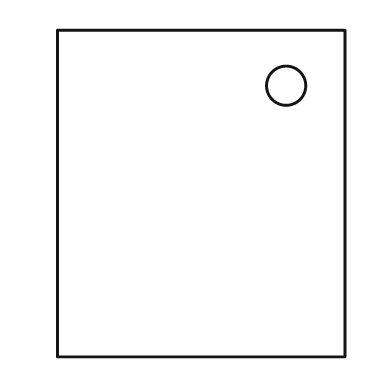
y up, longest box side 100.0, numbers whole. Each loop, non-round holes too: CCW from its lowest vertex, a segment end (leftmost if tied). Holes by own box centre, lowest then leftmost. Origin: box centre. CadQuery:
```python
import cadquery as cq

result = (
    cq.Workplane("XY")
    .moveTo(-44.0, -50.0)
    .lineTo(44.0, -50.0)
    .lineTo(44.0, 50.0)
    .lineTo(-44.0, 50.0)
    .close()
    .moveTo(26.0, 33.0)
    .circle(6.0)
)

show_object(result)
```